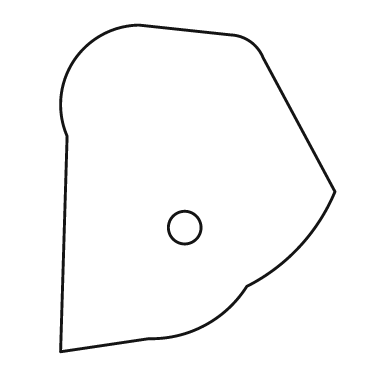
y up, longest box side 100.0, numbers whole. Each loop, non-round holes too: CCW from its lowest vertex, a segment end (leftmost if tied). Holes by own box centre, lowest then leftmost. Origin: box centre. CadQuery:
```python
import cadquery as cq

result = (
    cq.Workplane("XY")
    .moveTo(-42.0, -50.0)
    .lineTo(-15.0, -46.0)
    .threePointArc((2.0, -42.0), (15.0, -30.0))
    .threePointArc((31.0, -18.0), (42.0, -1.0))
    .lineTo(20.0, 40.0)
    .threePointArc((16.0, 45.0), (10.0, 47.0))
    .lineTo(-18.0, 50.0)
    .threePointArc((-38.0, 39.0), (-40.0, 16.0))
    .close()
    .moveTo(-4.0, -12.0)
    .circle(5.0)
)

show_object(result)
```